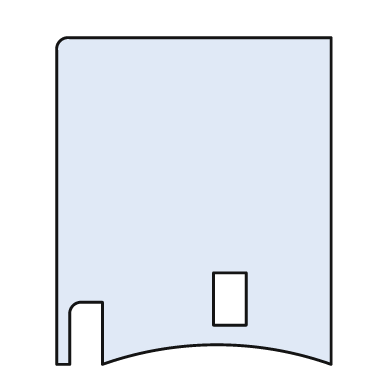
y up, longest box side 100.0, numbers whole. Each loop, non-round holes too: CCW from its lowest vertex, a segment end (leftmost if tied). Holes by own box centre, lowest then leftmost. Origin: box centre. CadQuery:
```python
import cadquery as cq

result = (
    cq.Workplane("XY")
    .moveTo(-42.0, -50.0)
    .lineTo(-38.0, -50.0)
    .lineTo(-38.0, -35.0)
    .threePointArc((-37.0, -32.0), (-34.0, -31.0))
    .lineTo(-28.0, -31.0)
    .lineTo(-28.0, -50.0)
    .threePointArc((7.0, -44.0), (42.0, -50.0))
    .lineTo(42.0, 50.0)
    .lineTo(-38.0, 50.0)
    .threePointArc((-41.0, 49.0), (-42.0, 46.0))
    .close()
    .moveTo(6.0, -38.0)
    .lineTo(16.0, -38.0)
    .lineTo(16.0, -22.0)
    .lineTo(6.0, -22.0)
    .close()
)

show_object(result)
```